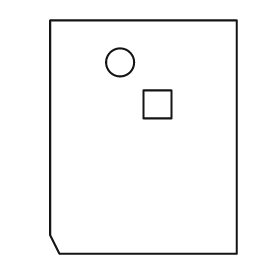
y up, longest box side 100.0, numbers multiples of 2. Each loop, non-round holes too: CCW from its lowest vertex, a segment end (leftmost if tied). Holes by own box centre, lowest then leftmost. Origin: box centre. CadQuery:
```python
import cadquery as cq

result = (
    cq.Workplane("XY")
    .moveTo(-36.0, -50.0)
    .lineTo(40.0, -50.0)
    .lineTo(40.0, 50.0)
    .lineTo(-40.0, 50.0)
    .lineTo(-40.0, -42.0)
    .close()
    .moveTo(0.0, 8.0)
    .lineTo(12.0, 8.0)
    .lineTo(12.0, 20.0)
    .lineTo(0.0, 20.0)
    .close()
    .moveTo(-10.0, 32.0)
    .circle(6.0)
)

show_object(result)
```